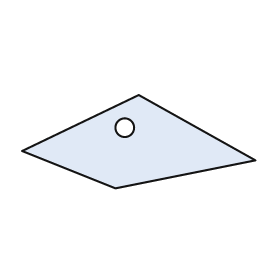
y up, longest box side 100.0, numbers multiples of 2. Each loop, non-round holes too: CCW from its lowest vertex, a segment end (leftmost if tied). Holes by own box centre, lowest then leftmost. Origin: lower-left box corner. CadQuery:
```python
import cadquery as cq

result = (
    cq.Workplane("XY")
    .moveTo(40.0, 0.0)
    .lineTo(100.0, 12.0)
    .lineTo(50.0, 40.0)
    .lineTo(0.0, 16.0)
    .close()
    .moveTo(44.0, 26.0)
    .circle(4.0)
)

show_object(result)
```